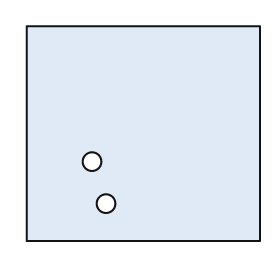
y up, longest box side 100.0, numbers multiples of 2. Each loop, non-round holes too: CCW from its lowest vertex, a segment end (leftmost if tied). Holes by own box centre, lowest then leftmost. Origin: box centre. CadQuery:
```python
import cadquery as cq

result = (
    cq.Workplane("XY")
    .moveTo(-50.0, -46.0)
    .lineTo(50.0, -46.0)
    .lineTo(50.0, 46.0)
    .lineTo(-50.0, 46.0)
    .close()
    .moveTo(-16.0, -30.0)
    .circle(4.0)
    .moveTo(-22.0, -12.0)
    .circle(4.0)
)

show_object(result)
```